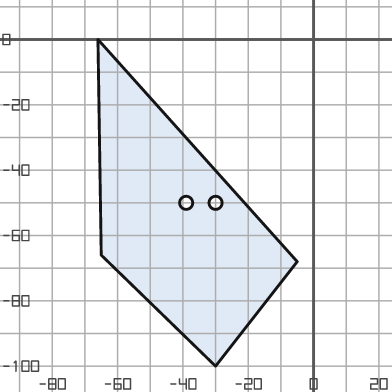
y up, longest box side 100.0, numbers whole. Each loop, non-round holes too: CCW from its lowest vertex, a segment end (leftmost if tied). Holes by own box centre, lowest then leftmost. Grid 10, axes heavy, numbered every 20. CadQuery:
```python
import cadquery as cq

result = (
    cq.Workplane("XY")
    .moveTo(-30.0, -100.0)
    .lineTo(-5.0, -68.0)
    .lineTo(-66.0, 0.0)
    .lineTo(-65.0, -66.0)
    .close()
    .moveTo(-39.0, -50.0)
    .circle(2.0)
    .moveTo(-30.0, -50.0)
    .circle(2.0)
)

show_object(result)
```